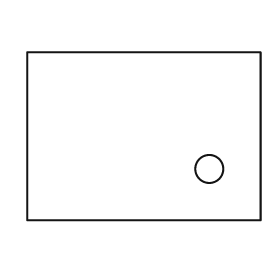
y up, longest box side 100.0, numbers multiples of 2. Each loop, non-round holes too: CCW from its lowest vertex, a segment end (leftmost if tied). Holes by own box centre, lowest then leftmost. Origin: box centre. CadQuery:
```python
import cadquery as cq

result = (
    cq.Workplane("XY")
    .moveTo(-50.0, -36.0)
    .lineTo(50.0, -36.0)
    .lineTo(50.0, 36.0)
    .lineTo(-50.0, 36.0)
    .close()
    .moveTo(28.0, -14.0)
    .circle(6.0)
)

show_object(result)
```